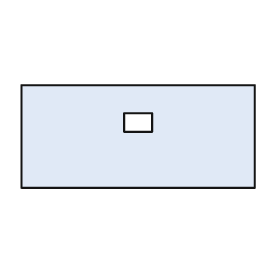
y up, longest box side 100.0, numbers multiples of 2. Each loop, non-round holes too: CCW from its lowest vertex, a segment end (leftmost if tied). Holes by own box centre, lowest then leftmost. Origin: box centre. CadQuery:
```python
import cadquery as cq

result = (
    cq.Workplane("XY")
    .moveTo(-50.0, -22.0)
    .lineTo(50.0, -22.0)
    .lineTo(50.0, 22.0)
    .lineTo(-50.0, 22.0)
    .close()
    .moveTo(-6.0, 2.0)
    .lineTo(6.0, 2.0)
    .lineTo(6.0, 10.0)
    .lineTo(-6.0, 10.0)
    .close()
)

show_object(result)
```